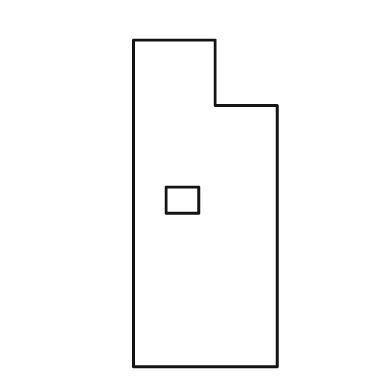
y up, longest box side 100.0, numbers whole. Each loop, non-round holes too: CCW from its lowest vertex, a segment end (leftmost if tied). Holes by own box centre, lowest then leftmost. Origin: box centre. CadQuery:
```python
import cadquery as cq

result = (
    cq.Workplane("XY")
    .moveTo(-22.0, -50.0)
    .lineTo(22.0, -50.0)
    .lineTo(22.0, 30.0)
    .lineTo(3.0, 30.0)
    .lineTo(3.0, 50.0)
    .lineTo(-22.0, 50.0)
    .close()
    .moveTo(-12.0, -3.0)
    .lineTo(-2.0, -3.0)
    .lineTo(-2.0, 5.0)
    .lineTo(-12.0, 5.0)
    .close()
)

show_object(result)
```